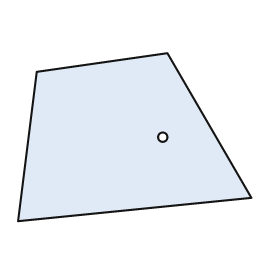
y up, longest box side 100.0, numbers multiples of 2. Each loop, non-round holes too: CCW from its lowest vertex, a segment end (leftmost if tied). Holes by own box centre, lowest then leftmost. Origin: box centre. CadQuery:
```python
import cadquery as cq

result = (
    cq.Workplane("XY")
    .moveTo(-50.0, -36.0)
    .lineTo(50.0, -26.0)
    .lineTo(14.0, 36.0)
    .lineTo(-42.0, 28.0)
    .close()
    .moveTo(12.0, 0.0)
    .circle(2.0)
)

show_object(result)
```